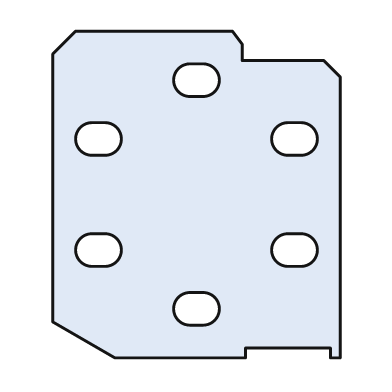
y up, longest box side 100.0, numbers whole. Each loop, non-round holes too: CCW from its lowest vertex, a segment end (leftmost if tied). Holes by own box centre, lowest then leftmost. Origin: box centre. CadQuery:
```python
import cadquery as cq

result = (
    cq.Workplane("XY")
    .moveTo(-25.0, -50.0)
    .lineTo(15.0, -50.0)
    .lineTo(15.0, -47.0)
    .lineTo(41.0, -47.0)
    .lineTo(41.0, -50.0)
    .lineTo(44.0, -50.0)
    .lineTo(44.0, 36.0)
    .lineTo(39.0, 41.0)
    .lineTo(14.0, 41.0)
    .lineTo(14.0, 46.0)
    .lineTo(11.0, 50.0)
    .lineTo(-37.0, 50.0)
    .lineTo(-44.0, 43.0)
    .lineTo(-44.0, -39.0)
    .close()
    .moveTo(-2.0, -40.0)
    .lineTo(2.0, -40.0)
    .threePointArc((7.0, -35.0), (2.0, -30.0))
    .lineTo(-2.0, -30.0)
    .threePointArc((-7.0, -35.0), (-2.0, -40.0))
    .close()
    .moveTo(-32.0, -22.0)
    .lineTo(-28.0, -22.0)
    .threePointArc((-23.0, -17.0), (-28.0, -12.0))
    .lineTo(-32.0, -12.0)
    .threePointArc((-37.0, -17.0), (-32.0, -22.0))
    .close()
    .moveTo(28.0, -22.0)
    .lineTo(32.0, -22.0)
    .threePointArc((37.0, -17.0), (32.0, -12.0))
    .lineTo(28.0, -12.0)
    .threePointArc((23.0, -17.0), (28.0, -22.0))
    .close()
    .moveTo(-32.0, 12.0)
    .lineTo(-28.0, 12.0)
    .threePointArc((-23.0, 17.0), (-28.0, 22.0))
    .lineTo(-32.0, 22.0)
    .threePointArc((-37.0, 17.0), (-32.0, 12.0))
    .close()
    .moveTo(28.0, 12.0)
    .lineTo(32.0, 12.0)
    .threePointArc((37.0, 17.0), (32.0, 22.0))
    .lineTo(28.0, 22.0)
    .threePointArc((23.0, 17.0), (28.0, 12.0))
    .close()
    .moveTo(-2.0, 30.0)
    .lineTo(2.0, 30.0)
    .threePointArc((7.0, 35.0), (2.0, 40.0))
    .lineTo(-2.0, 40.0)
    .threePointArc((-7.0, 35.0), (-2.0, 30.0))
    .close()
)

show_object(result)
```